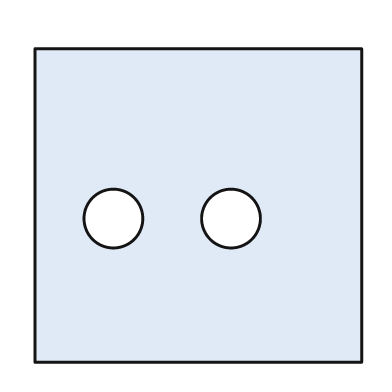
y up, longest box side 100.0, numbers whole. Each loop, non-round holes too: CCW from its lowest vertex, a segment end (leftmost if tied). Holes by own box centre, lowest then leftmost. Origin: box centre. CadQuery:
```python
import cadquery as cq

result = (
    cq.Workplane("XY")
    .moveTo(-50.0, -48.0)
    .lineTo(50.0, -48.0)
    .lineTo(50.0, 48.0)
    .lineTo(-50.0, 48.0)
    .close()
    .moveTo(-26.0, -4.0)
    .circle(9.0)
    .moveTo(10.0, -4.0)
    .circle(9.0)
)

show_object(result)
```